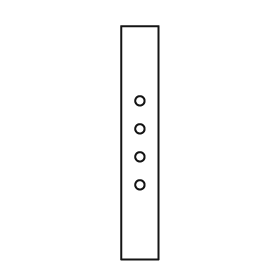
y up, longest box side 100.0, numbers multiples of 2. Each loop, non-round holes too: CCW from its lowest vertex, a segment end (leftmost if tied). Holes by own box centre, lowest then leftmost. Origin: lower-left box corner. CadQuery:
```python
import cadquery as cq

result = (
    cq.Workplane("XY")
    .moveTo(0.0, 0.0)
    .lineTo(16.0, 0.0)
    .lineTo(16.0, 100.0)
    .lineTo(0.0, 100.0)
    .close()
    .moveTo(8.0, 32.0)
    .circle(2.0)
    .moveTo(8.0, 44.0)
    .circle(2.0)
    .moveTo(8.0, 56.0)
    .circle(2.0)
    .moveTo(8.0, 68.0)
    .circle(2.0)
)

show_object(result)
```